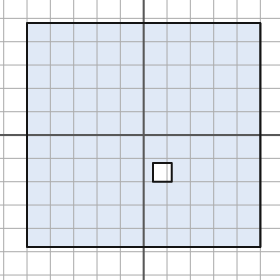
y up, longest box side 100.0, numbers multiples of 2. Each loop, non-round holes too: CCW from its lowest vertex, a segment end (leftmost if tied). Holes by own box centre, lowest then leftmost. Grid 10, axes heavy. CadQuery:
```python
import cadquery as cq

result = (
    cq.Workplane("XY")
    .moveTo(-50.0, -48.0)
    .lineTo(50.0, -48.0)
    .lineTo(50.0, 48.0)
    .lineTo(-50.0, 48.0)
    .close()
    .moveTo(4.0, -20.0)
    .lineTo(12.0, -20.0)
    .lineTo(12.0, -12.0)
    .lineTo(4.0, -12.0)
    .close()
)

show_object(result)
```